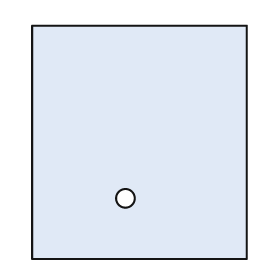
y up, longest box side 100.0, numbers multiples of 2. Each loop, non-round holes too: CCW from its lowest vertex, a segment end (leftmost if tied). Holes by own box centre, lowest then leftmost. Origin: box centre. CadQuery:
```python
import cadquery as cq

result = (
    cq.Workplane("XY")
    .moveTo(-46.0, -50.0)
    .lineTo(46.0, -50.0)
    .lineTo(46.0, 50.0)
    .lineTo(-46.0, 50.0)
    .close()
    .moveTo(-6.0, -24.0)
    .circle(4.0)
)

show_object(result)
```